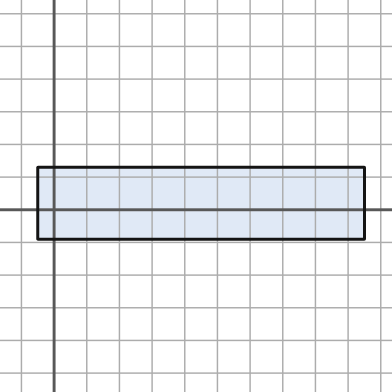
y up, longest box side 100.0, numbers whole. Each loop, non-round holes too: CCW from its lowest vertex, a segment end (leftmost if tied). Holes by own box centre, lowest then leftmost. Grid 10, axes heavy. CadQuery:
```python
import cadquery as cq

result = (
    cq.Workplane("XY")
    .moveTo(-5.0, -9.0)
    .lineTo(95.0, -9.0)
    .lineTo(95.0, 13.0)
    .lineTo(-5.0, 13.0)
    .close()
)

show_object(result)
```